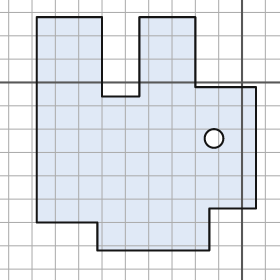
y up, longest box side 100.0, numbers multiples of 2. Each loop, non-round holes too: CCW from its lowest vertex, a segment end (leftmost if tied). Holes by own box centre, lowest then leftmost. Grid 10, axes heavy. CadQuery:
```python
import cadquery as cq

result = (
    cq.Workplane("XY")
    .moveTo(-62.0, -72.0)
    .lineTo(-14.0, -72.0)
    .lineTo(-14.0, -54.0)
    .lineTo(6.0, -54.0)
    .lineTo(6.0, -2.0)
    .lineTo(-20.0, -2.0)
    .lineTo(-20.0, 28.0)
    .lineTo(-44.0, 28.0)
    .lineTo(-44.0, -6.0)
    .lineTo(-60.0, -6.0)
    .lineTo(-60.0, 28.0)
    .lineTo(-88.0, 28.0)
    .lineTo(-88.0, -60.0)
    .lineTo(-62.0, -60.0)
    .close()
    .moveTo(-12.0, -24.0)
    .circle(4.0)
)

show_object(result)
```